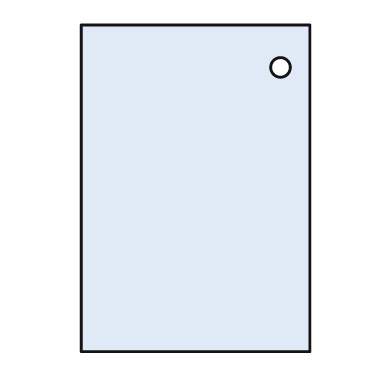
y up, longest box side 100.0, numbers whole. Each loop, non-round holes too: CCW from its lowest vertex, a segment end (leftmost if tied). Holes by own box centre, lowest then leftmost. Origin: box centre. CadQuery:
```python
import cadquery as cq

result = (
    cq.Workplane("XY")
    .moveTo(-35.0, -50.0)
    .lineTo(35.0, -50.0)
    .lineTo(35.0, 50.0)
    .lineTo(-35.0, 50.0)
    .close()
    .moveTo(26.0, 37.0)
    .circle(3.0)
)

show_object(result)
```